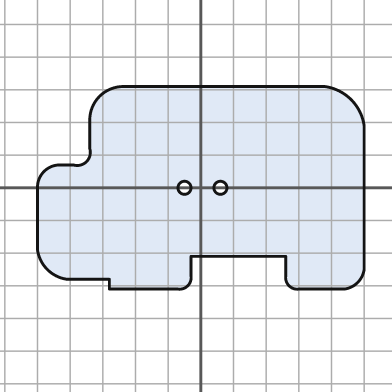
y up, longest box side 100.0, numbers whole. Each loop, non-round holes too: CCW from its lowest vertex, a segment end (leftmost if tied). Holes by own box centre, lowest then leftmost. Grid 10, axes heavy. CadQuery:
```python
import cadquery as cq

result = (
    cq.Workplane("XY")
    .moveTo(-28.0, -31.0)
    .lineTo(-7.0, -31.0)
    .threePointArc((-4.0, -30.0), (-3.0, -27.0))
    .lineTo(-3.0, -21.0)
    .lineTo(26.0, -21.0)
    .lineTo(26.0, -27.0)
    .threePointArc((27.0, -30.0), (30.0, -31.0))
    .lineTo(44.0, -31.0)
    .threePointArc((48.0, -29.0), (50.0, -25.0))
    .lineTo(50.0, 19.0)
    .threePointArc((46.0, 27.0), (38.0, 31.0))
    .lineTo(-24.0, 31.0)
    .threePointArc((-31.0, 28.0), (-34.0, 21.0))
    .lineTo(-34.0, 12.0)
    .threePointArc((-35.0, 8.0), (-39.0, 7.0))
    .lineTo(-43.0, 7.0)
    .threePointArc((-48.0, 5.0), (-50.0, 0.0))
    .lineTo(-50.0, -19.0)
    .threePointArc((-47.0, -25.0), (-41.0, -28.0))
    .lineTo(-28.0, -28.0)
    .close()
    .moveTo(-5.0, 0.0)
    .circle(2.0)
    .moveTo(6.0, 0.0)
    .circle(2.0)
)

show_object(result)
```